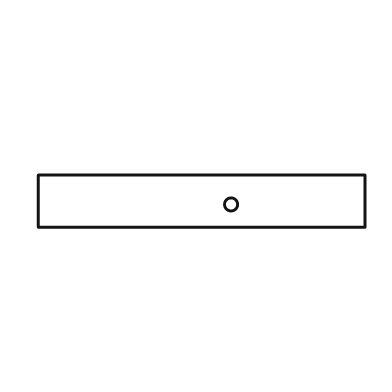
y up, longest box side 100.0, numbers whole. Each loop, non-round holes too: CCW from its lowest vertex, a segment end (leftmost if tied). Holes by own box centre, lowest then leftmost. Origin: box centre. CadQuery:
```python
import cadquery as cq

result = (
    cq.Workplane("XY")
    .moveTo(-50.0, -8.0)
    .lineTo(50.0, -8.0)
    .lineTo(50.0, 8.0)
    .lineTo(-50.0, 8.0)
    .close()
    .moveTo(9.0, -1.0)
    .circle(2.0)
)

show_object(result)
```